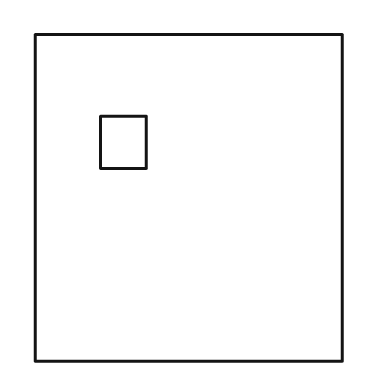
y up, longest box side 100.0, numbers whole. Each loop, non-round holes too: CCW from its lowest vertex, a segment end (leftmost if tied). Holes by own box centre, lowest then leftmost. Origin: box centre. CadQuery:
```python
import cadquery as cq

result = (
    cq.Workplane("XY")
    .moveTo(-47.0, -50.0)
    .lineTo(47.0, -50.0)
    .lineTo(47.0, 50.0)
    .lineTo(-47.0, 50.0)
    .close()
    .moveTo(-27.0, 9.0)
    .lineTo(-13.0, 9.0)
    .lineTo(-13.0, 25.0)
    .lineTo(-27.0, 25.0)
    .close()
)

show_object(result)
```